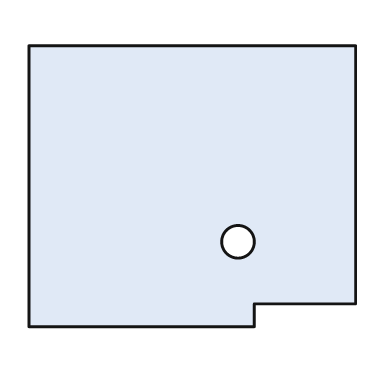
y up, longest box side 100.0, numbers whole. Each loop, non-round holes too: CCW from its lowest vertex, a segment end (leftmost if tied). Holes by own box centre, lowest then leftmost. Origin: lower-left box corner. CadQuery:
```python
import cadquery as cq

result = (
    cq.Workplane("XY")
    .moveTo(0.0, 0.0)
    .lineTo(69.0, 0.0)
    .lineTo(69.0, 7.0)
    .lineTo(100.0, 7.0)
    .lineTo(100.0, 86.0)
    .lineTo(0.0, 86.0)
    .close()
    .moveTo(64.0, 26.0)
    .circle(5.0)
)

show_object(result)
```